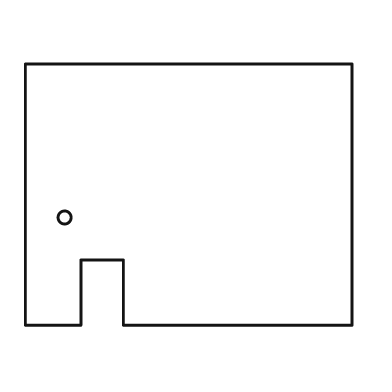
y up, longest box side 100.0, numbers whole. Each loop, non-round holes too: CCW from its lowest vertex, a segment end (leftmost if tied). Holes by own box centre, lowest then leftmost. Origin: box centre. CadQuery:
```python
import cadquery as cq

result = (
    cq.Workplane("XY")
    .moveTo(-50.0, -40.0)
    .lineTo(-33.0, -40.0)
    .lineTo(-33.0, -20.0)
    .lineTo(-20.0, -20.0)
    .lineTo(-20.0, -40.0)
    .lineTo(50.0, -40.0)
    .lineTo(50.0, 40.0)
    .lineTo(-50.0, 40.0)
    .close()
    .moveTo(-38.0, -7.0)
    .circle(2.0)
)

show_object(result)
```